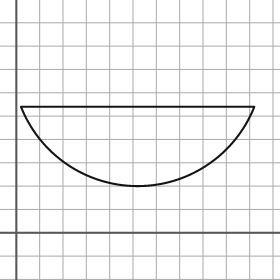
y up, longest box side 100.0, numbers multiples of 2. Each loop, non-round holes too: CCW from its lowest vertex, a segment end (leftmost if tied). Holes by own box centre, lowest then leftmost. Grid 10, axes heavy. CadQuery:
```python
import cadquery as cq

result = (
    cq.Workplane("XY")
    .moveTo(2.0, 54.0)
    .threePointArc((52.0, 20.0), (102.0, 54.0))
    .close()
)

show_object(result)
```